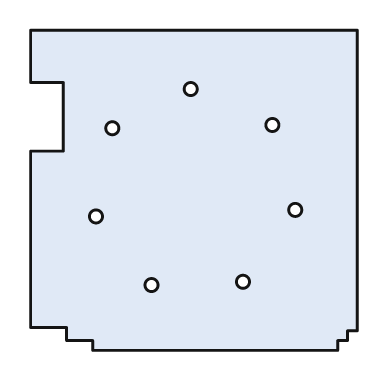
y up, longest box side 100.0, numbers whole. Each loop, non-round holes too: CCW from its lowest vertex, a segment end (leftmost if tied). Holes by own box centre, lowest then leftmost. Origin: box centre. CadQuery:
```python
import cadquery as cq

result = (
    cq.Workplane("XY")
    .moveTo(-31.0, -49.0)
    .lineTo(44.0, -49.0)
    .lineTo(44.0, -46.0)
    .lineTo(47.0, -46.0)
    .lineTo(47.0, -43.0)
    .lineTo(50.0, -43.0)
    .lineTo(50.0, 49.0)
    .lineTo(-50.0, 49.0)
    .lineTo(-50.0, 33.0)
    .lineTo(-40.0, 33.0)
    .lineTo(-40.0, 12.0)
    .lineTo(-50.0, 12.0)
    .lineTo(-50.0, -42.0)
    .lineTo(-39.0, -42.0)
    .lineTo(-39.0, -46.0)
    .lineTo(-31.0, -46.0)
    .close()
    .moveTo(-13.0, -29.0)
    .circle(2.0)
    .moveTo(15.0, -28.0)
    .circle(2.0)
    .moveTo(-30.0, -8.0)
    .circle(2.0)
    .moveTo(31.0, -6.0)
    .circle(2.0)
    .moveTo(-25.0, 19.0)
    .circle(2.0)
    .moveTo(24.0, 20.0)
    .circle(2.0)
    .moveTo(-1.0, 31.0)
    .circle(2.0)
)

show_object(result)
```